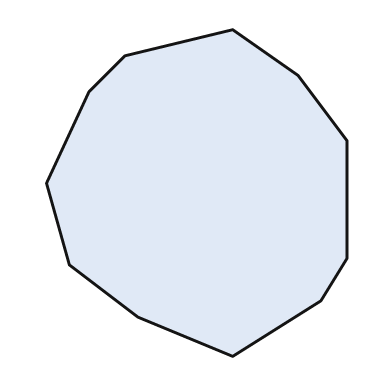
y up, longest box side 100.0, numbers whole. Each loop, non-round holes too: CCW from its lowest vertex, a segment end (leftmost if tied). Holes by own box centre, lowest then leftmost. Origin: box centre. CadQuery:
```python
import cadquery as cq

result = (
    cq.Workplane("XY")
    .moveTo(11.0, -50.0)
    .lineTo(38.0, -33.0)
    .lineTo(46.0, -20.0)
    .lineTo(46.0, 16.0)
    .lineTo(31.0, 36.0)
    .lineTo(11.0, 50.0)
    .lineTo(-22.0, 42.0)
    .lineTo(-33.0, 31.0)
    .lineTo(-46.0, 3.0)
    .lineTo(-39.0, -22.0)
    .lineTo(-18.0, -38.0)
    .close()
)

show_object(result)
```